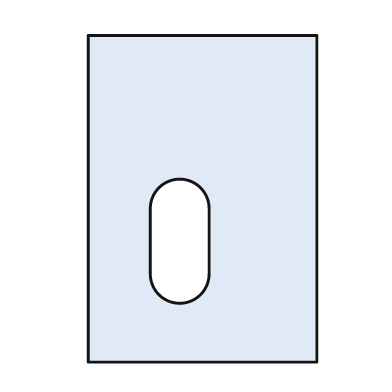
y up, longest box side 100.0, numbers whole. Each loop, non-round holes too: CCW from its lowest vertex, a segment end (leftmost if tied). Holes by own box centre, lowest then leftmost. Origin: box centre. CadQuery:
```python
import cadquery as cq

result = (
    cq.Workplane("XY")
    .moveTo(-35.0, -50.0)
    .lineTo(35.0, -50.0)
    .lineTo(35.0, 50.0)
    .lineTo(-35.0, 50.0)
    .close()
    .moveTo(-16.0, -23.0)
    .threePointArc((-7.0, -32.0), (2.0, -23.0))
    .lineTo(2.0, -3.0)
    .threePointArc((-7.0, 6.0), (-16.0, -3.0))
    .close()
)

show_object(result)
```